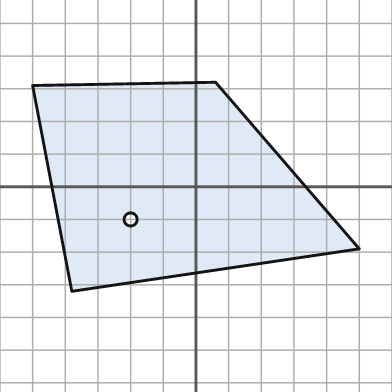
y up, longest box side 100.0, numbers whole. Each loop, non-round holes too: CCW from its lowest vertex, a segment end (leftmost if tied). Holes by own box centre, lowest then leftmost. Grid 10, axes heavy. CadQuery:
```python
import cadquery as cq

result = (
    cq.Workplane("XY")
    .moveTo(-38.0, -32.0)
    .lineTo(50.0, -19.0)
    .lineTo(6.0, 32.0)
    .lineTo(-50.0, 31.0)
    .close()
    .moveTo(-20.0, -10.0)
    .circle(2.0)
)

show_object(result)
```